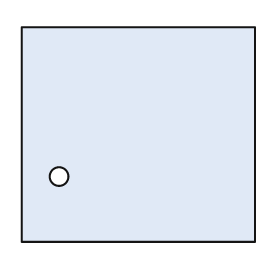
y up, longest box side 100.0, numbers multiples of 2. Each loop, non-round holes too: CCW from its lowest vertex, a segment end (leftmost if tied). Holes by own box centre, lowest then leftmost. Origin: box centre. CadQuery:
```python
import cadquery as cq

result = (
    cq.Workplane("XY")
    .moveTo(-50.0, -46.0)
    .lineTo(50.0, -46.0)
    .lineTo(50.0, 46.0)
    .lineTo(-50.0, 46.0)
    .close()
    .moveTo(-34.0, -18.0)
    .circle(4.0)
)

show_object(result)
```